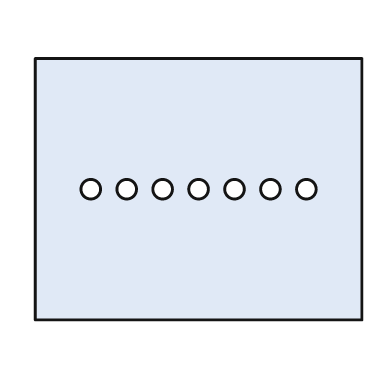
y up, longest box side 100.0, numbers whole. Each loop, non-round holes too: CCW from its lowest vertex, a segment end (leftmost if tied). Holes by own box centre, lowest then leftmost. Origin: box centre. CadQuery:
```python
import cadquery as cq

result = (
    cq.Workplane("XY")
    .moveTo(-50.0, -40.0)
    .lineTo(50.0, -40.0)
    .lineTo(50.0, 40.0)
    .lineTo(-50.0, 40.0)
    .close()
    .moveTo(-33.0, 0.0)
    .circle(3.0)
    .moveTo(-22.0, 0.0)
    .circle(3.0)
    .moveTo(-11.0, 0.0)
    .circle(3.0)
    .moveTo(0.0, 0.0)
    .circle(3.0)
    .moveTo(11.0, 0.0)
    .circle(3.0)
    .moveTo(22.0, 0.0)
    .circle(3.0)
    .moveTo(33.0, 0.0)
    .circle(3.0)
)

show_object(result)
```